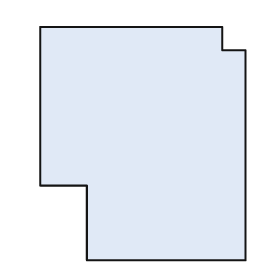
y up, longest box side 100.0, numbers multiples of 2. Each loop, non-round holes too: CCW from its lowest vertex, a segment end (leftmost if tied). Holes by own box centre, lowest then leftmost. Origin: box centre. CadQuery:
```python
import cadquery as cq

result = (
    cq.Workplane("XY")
    .moveTo(-24.0, -50.0)
    .lineTo(44.0, -50.0)
    .lineTo(44.0, 40.0)
    .lineTo(34.0, 40.0)
    .lineTo(34.0, 50.0)
    .lineTo(-44.0, 50.0)
    .lineTo(-44.0, -18.0)
    .lineTo(-24.0, -18.0)
    .close()
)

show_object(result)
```